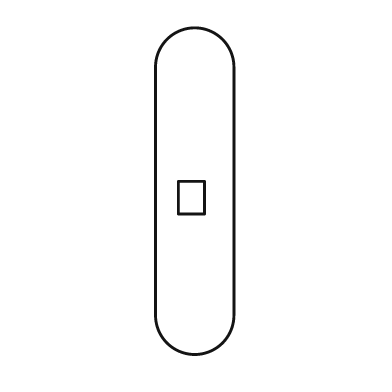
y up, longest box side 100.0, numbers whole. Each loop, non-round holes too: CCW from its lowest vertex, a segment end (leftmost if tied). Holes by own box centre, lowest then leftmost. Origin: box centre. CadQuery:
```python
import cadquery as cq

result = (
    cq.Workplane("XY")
    .moveTo(-12.0, -38.0)
    .threePointArc((0.0, -50.0), (12.0, -38.0))
    .lineTo(12.0, 38.0)
    .threePointArc((0.0, 50.0), (-12.0, 38.0))
    .close()
    .moveTo(-5.0, -7.0)
    .lineTo(3.0, -7.0)
    .lineTo(3.0, 3.0)
    .lineTo(-5.0, 3.0)
    .close()
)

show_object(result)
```